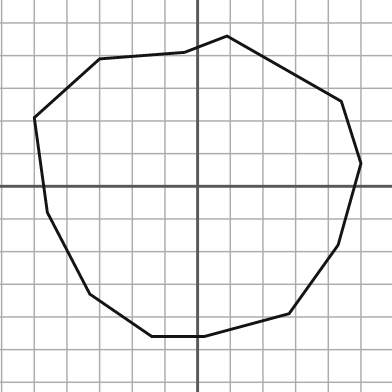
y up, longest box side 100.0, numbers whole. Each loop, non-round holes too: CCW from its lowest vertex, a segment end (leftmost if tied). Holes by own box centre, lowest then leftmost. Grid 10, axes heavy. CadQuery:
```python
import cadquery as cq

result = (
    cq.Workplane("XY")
    .moveTo(-14.0, -46.0)
    .lineTo(2.0, -46.0)
    .lineTo(28.0, -39.0)
    .lineTo(43.0, -18.0)
    .lineTo(50.0, 7.0)
    .lineTo(44.0, 26.0)
    .lineTo(9.0, 46.0)
    .lineTo(-4.0, 41.0)
    .lineTo(-30.0, 39.0)
    .lineTo(-50.0, 21.0)
    .lineTo(-46.0, -8.0)
    .lineTo(-33.0, -33.0)
    .close()
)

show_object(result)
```